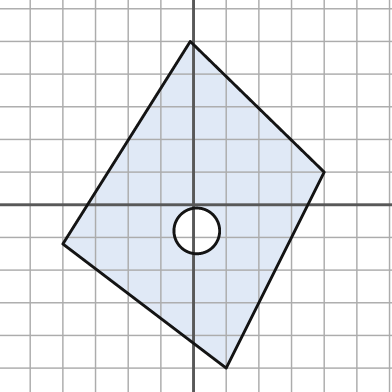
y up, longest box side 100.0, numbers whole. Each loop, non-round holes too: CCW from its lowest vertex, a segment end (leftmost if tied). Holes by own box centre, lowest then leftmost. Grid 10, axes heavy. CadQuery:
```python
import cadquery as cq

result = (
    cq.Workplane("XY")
    .moveTo(10.0, -50.0)
    .lineTo(40.0, 10.0)
    .lineTo(-1.0, 50.0)
    .lineTo(-40.0, -12.0)
    .close()
    .moveTo(1.0, -8.0)
    .circle(7.0)
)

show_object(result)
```